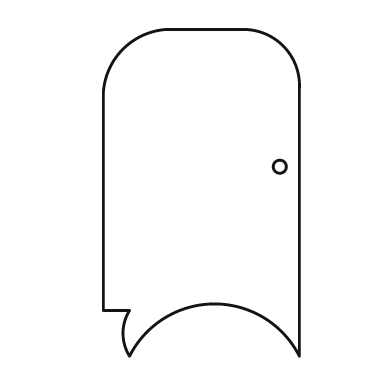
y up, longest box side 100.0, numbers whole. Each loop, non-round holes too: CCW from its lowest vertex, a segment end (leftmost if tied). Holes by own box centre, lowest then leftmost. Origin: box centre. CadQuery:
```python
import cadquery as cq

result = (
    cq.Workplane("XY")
    .moveTo(-22.0, -50.0)
    .threePointArc((4.0, -34.0), (30.0, -50.0))
    .lineTo(30.0, 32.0)
    .threePointArc((25.0, 45.0), (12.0, 50.0))
    .lineTo(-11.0, 50.0)
    .threePointArc((-24.0, 44.0), (-30.0, 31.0))
    .lineTo(-30.0, -36.0)
    .lineTo(-22.0, -36.0)
    .threePointArc((-24.0, -43.0), (-22.0, -50.0))
    .close()
    .moveTo(24.0, 8.0)
    .circle(2.0)
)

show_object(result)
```